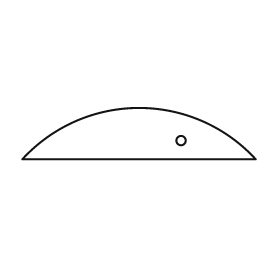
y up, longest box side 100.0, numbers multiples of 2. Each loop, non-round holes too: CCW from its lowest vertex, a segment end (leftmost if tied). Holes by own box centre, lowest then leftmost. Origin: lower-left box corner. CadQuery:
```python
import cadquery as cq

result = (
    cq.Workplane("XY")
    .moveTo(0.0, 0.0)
    .lineTo(100.0, 0.0)
    .threePointArc((50.0, 22.0), (0.0, 0.0))
    .close()
    .moveTo(68.0, 8.0)
    .circle(2.0)
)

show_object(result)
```